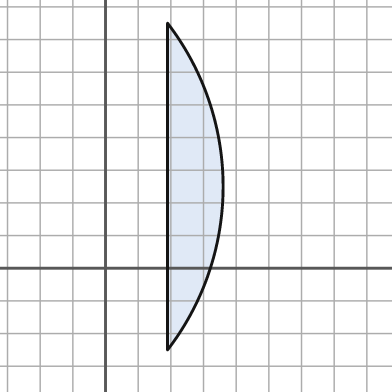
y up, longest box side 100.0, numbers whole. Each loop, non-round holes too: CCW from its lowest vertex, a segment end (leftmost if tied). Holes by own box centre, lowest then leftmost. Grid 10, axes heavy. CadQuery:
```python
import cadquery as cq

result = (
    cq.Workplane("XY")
    .moveTo(19.0, -25.0)
    .threePointArc((36.0, 25.0), (19.0, 75.0))
    .close()
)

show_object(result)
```